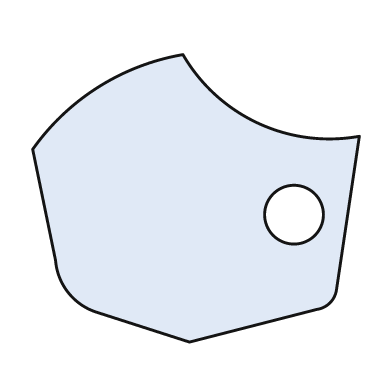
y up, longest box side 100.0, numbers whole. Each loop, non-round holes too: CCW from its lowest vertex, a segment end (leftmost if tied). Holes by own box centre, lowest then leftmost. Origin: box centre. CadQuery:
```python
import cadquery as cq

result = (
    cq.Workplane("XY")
    .moveTo(-2.0, -44.0)
    .lineTo(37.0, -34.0)
    .threePointArc((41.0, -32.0), (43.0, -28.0))
    .lineTo(50.0, 19.0)
    .threePointArc((19.0, 23.0), (-4.0, 44.0))
    .threePointArc((-30.0, 34.0), (-50.0, 15.0))
    .lineTo(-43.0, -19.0)
    .threePointArc((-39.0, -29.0), (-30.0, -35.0))
    .close()
    .moveTo(30.0, -5.0)
    .circle(9.0)
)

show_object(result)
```